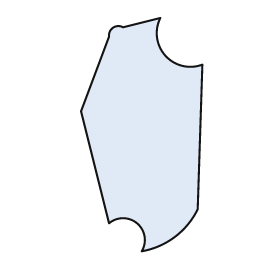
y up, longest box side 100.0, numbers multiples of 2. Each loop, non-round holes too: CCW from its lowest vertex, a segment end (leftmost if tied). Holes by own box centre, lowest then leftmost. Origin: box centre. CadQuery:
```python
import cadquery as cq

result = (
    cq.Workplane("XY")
    .moveTo(0.0, -50.0)
    .threePointArc((14.0, -44.0), (24.0, -32.0))
    .lineTo(26.0, 30.0)
    .threePointArc((10.0, 34.0), (8.0, 50.0))
    .lineTo(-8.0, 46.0)
    .threePointArc((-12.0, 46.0), (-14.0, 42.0))
    .lineTo(-26.0, 10.0)
    .lineTo(-14.0, -38.0)
    .threePointArc((-2.0, -38.0), (0.0, -50.0))
    .close()
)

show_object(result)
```